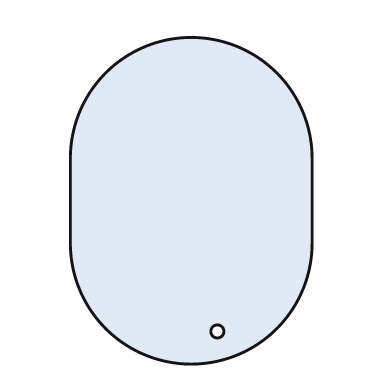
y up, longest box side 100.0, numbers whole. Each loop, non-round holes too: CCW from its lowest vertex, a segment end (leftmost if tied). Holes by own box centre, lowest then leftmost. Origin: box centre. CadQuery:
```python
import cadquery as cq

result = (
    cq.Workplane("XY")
    .moveTo(-37.0, -13.0)
    .threePointArc((0.0, -50.0), (37.0, -13.0))
    .lineTo(37.0, 13.0)
    .threePointArc((0.0, 50.0), (-37.0, 13.0))
    .close()
    .moveTo(8.0, -40.0)
    .circle(2.0)
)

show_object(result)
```